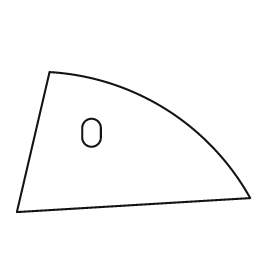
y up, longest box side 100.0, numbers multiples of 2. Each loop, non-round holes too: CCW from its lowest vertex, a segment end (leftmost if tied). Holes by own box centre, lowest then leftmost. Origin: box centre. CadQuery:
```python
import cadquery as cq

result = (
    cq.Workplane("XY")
    .moveTo(-50.0, -30.0)
    .lineTo(50.0, -24.0)
    .threePointArc((14.0, 14.0), (-36.0, 30.0))
    .close()
    .moveTo(-22.0, 2.0)
    .threePointArc((-18.0, -2.0), (-14.0, 2.0))
    .lineTo(-14.0, 6.0)
    .threePointArc((-18.0, 10.0), (-22.0, 6.0))
    .close()
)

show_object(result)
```